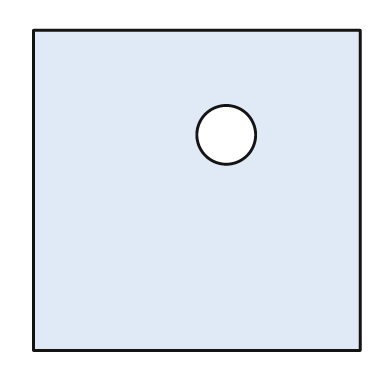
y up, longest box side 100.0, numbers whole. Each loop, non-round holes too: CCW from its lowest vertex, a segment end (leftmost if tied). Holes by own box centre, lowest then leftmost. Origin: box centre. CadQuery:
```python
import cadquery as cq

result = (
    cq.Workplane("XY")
    .moveTo(-50.0, -49.0)
    .lineTo(50.0, -49.0)
    .lineTo(50.0, 49.0)
    .lineTo(-50.0, 49.0)
    .close()
    .moveTo(9.0, 17.0)
    .circle(9.0)
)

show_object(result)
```